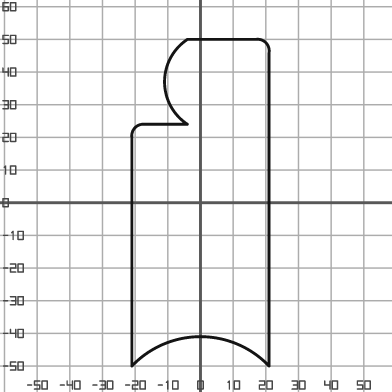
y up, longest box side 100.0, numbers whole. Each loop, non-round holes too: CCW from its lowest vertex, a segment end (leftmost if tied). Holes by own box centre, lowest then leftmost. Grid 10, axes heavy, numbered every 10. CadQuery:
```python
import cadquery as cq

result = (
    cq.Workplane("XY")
    .moveTo(-21.0, -50.0)
    .threePointArc((0.0, -41.0), (21.0, -50.0))
    .lineTo(21.0, 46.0)
    .threePointArc((20.0, 49.0), (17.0, 50.0))
    .lineTo(-4.0, 50.0)
    .threePointArc((-11.0, 37.0), (-4.0, 24.0))
    .lineTo(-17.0, 24.0)
    .threePointArc((-20.0, 23.0), (-21.0, 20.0))
    .close()
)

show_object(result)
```